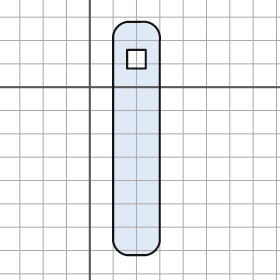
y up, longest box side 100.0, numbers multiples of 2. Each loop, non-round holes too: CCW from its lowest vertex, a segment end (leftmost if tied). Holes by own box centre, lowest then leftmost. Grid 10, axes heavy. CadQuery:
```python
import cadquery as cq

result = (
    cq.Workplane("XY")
    .moveTo(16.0, -72.0)
    .lineTo(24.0, -72.0)
    .threePointArc((28.0, -70.0), (30.0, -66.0))
    .lineTo(30.0, 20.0)
    .threePointArc((28.0, 26.0), (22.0, 28.0))
    .lineTo(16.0, 28.0)
    .threePointArc((12.0, 26.0), (10.0, 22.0))
    .lineTo(10.0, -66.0)
    .threePointArc((12.0, -70.0), (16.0, -72.0))
    .close()
    .moveTo(16.0, 8.0)
    .lineTo(24.0, 8.0)
    .lineTo(24.0, 16.0)
    .lineTo(16.0, 16.0)
    .close()
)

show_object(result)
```